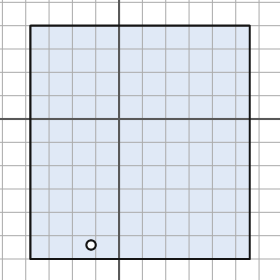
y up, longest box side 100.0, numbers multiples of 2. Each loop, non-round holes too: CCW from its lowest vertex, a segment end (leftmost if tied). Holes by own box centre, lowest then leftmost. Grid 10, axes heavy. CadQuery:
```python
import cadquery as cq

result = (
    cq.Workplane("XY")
    .moveTo(-38.0, -60.0)
    .lineTo(56.0, -60.0)
    .lineTo(56.0, 40.0)
    .lineTo(-38.0, 40.0)
    .close()
    .moveTo(-12.0, -54.0)
    .circle(2.0)
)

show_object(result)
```